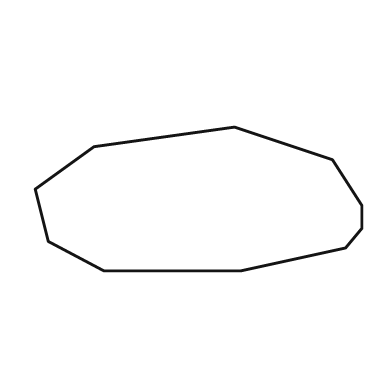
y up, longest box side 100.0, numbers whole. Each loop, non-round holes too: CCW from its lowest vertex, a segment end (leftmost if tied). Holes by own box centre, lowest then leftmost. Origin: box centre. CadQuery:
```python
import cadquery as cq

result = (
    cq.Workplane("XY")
    .moveTo(-29.0, -22.0)
    .lineTo(13.0, -22.0)
    .lineTo(45.0, -15.0)
    .lineTo(50.0, -9.0)
    .lineTo(50.0, -2.0)
    .lineTo(41.0, 12.0)
    .lineTo(11.0, 22.0)
    .lineTo(-32.0, 16.0)
    .lineTo(-50.0, 3.0)
    .lineTo(-46.0, -13.0)
    .close()
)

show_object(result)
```